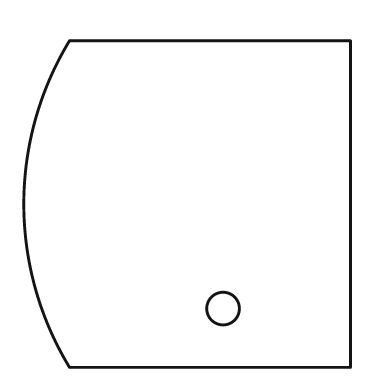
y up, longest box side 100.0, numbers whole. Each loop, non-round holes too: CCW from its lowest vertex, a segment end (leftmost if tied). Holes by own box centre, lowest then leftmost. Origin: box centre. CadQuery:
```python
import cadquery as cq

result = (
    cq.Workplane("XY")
    .moveTo(-36.0, -50.0)
    .lineTo(50.0, -50.0)
    .lineTo(50.0, 50.0)
    .lineTo(-36.0, 50.0)
    .threePointArc((-50.0, 0.0), (-36.0, -50.0))
    .close()
    .moveTo(11.0, -32.0)
    .circle(5.0)
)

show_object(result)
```